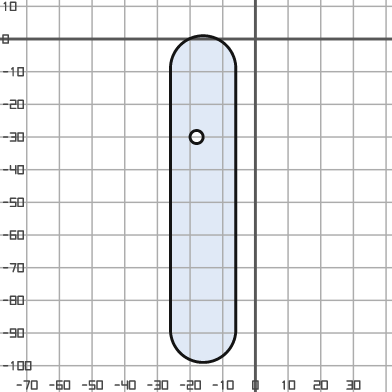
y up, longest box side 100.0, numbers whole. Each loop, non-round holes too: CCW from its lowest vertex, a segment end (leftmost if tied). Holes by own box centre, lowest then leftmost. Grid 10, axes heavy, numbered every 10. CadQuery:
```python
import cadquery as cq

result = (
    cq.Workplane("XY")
    .moveTo(-26.0, -89.0)
    .threePointArc((-16.0, -99.0), (-6.0, -89.0))
    .lineTo(-6.0, -9.0)
    .threePointArc((-16.0, 1.0), (-26.0, -9.0))
    .close()
    .moveTo(-18.0, -30.0)
    .circle(2.0)
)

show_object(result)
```